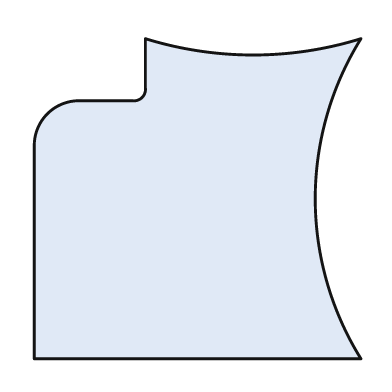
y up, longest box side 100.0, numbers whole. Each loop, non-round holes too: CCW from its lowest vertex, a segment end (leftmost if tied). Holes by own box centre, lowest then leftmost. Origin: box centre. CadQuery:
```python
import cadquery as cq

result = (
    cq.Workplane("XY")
    .moveTo(-50.0, -49.0)
    .lineTo(50.0, -49.0)
    .threePointArc((36.0, 0.0), (50.0, 49.0))
    .threePointArc((17.0, 44.0), (-16.0, 49.0))
    .lineTo(-16.0, 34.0)
    .threePointArc((-17.0, 31.0), (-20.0, 30.0))
    .lineTo(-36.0, 30.0)
    .threePointArc((-46.0, 26.0), (-50.0, 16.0))
    .close()
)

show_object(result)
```